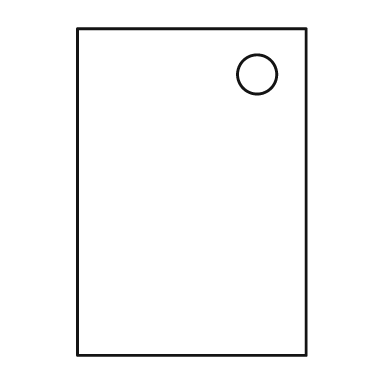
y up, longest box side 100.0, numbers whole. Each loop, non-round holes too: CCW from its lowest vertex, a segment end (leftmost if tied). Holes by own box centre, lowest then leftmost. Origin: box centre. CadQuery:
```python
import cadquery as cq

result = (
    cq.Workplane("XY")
    .moveTo(-35.0, -50.0)
    .lineTo(35.0, -50.0)
    .lineTo(35.0, 50.0)
    .lineTo(-35.0, 50.0)
    .close()
    .moveTo(20.0, 36.0)
    .circle(6.0)
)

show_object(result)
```